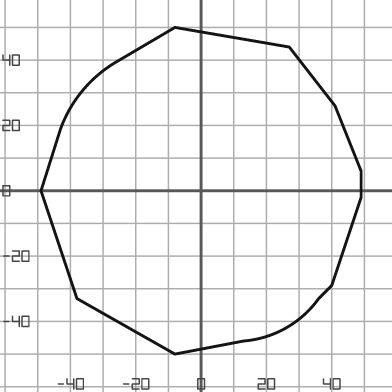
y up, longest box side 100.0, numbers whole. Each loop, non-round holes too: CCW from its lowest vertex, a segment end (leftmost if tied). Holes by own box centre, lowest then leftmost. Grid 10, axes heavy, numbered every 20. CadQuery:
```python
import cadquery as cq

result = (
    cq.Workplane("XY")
    .moveTo(-8.0, -50.0)
    .lineTo(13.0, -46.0)
    .threePointArc((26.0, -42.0), (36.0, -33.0))
    .lineTo(40.0, -29.0)
    .lineTo(49.0, -2.0)
    .lineTo(49.0, 6.0)
    .lineTo(41.0, 26.0)
    .lineTo(27.0, 44.0)
    .lineTo(-8.0, 50.0)
    .lineTo(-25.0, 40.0)
    .threePointArc((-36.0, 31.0), (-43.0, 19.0))
    .lineTo(-49.0, 0.0)
    .lineTo(-38.0, -33.0)
    .close()
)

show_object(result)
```